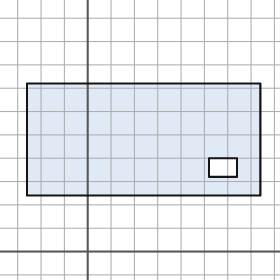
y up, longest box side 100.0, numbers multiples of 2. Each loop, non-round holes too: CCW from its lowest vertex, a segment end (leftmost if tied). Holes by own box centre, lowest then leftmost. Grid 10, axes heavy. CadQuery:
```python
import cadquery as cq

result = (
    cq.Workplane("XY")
    .moveTo(-26.0, 24.0)
    .lineTo(74.0, 24.0)
    .lineTo(74.0, 72.0)
    .lineTo(-26.0, 72.0)
    .close()
    .moveTo(52.0, 32.0)
    .lineTo(64.0, 32.0)
    .lineTo(64.0, 40.0)
    .lineTo(52.0, 40.0)
    .close()
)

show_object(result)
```